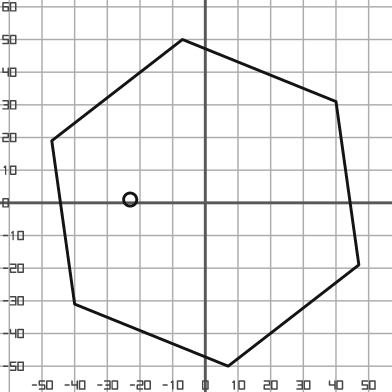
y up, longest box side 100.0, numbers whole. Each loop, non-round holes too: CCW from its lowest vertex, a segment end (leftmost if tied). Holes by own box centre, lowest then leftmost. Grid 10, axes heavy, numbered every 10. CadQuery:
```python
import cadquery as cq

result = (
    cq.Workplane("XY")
    .moveTo(7.0, -50.0)
    .lineTo(47.0, -19.0)
    .lineTo(40.0, 31.0)
    .lineTo(-7.0, 50.0)
    .lineTo(-47.0, 19.0)
    .lineTo(-40.0, -31.0)
    .close()
    .moveTo(-23.0, 1.0)
    .circle(2.0)
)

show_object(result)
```